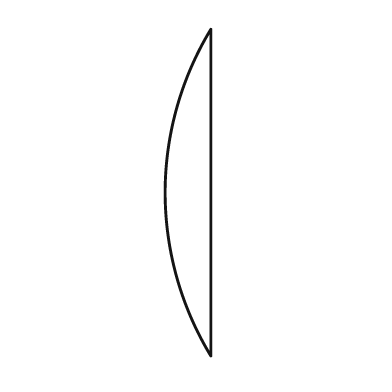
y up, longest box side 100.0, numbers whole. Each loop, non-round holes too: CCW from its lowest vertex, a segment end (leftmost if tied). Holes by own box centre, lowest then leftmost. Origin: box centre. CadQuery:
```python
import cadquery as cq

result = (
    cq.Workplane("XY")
    .moveTo(7.0, -50.0)
    .lineTo(7.0, 50.0)
    .threePointArc((-7.0, 0.0), (7.0, -50.0))
    .close()
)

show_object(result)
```